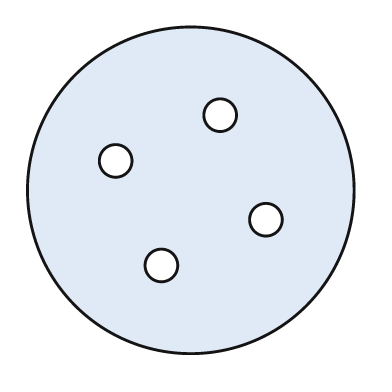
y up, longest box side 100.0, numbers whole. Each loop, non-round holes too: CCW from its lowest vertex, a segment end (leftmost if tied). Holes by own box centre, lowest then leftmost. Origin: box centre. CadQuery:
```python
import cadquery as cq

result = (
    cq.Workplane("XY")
    .moveTo(0.0, 0.0)
    .circle(50.0)
    .moveTo(-9.0, -23.0)
    .circle(5.0)
    .moveTo(23.0, -9.0)
    .circle(5.0)
    .moveTo(-23.0, 9.0)
    .circle(5.0)
    .moveTo(9.0, 23.0)
    .circle(5.0)
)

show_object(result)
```